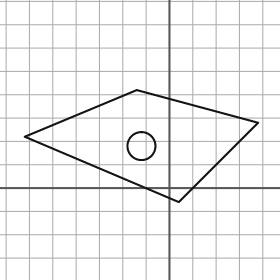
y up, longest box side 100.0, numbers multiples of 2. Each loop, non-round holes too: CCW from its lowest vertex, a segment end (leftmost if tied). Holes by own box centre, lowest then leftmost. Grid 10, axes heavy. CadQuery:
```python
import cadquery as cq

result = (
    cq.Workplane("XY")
    .moveTo(4.0, -6.0)
    .lineTo(38.0, 28.0)
    .lineTo(-14.0, 42.0)
    .lineTo(-62.0, 22.0)
    .close()
    .moveTo(-12.0, 18.0)
    .circle(6.0)
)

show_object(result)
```